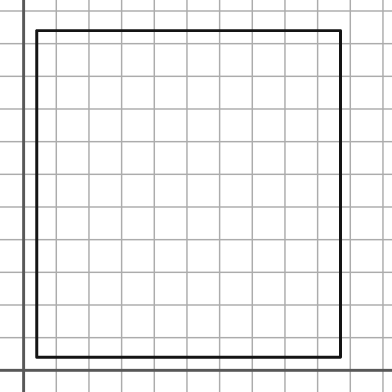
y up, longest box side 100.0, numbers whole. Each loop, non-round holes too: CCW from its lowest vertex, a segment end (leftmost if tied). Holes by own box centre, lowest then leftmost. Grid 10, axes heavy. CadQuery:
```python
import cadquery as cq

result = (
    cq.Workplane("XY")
    .moveTo(4.0, 4.0)
    .lineTo(97.0, 4.0)
    .lineTo(97.0, 104.0)
    .lineTo(4.0, 104.0)
    .close()
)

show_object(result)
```